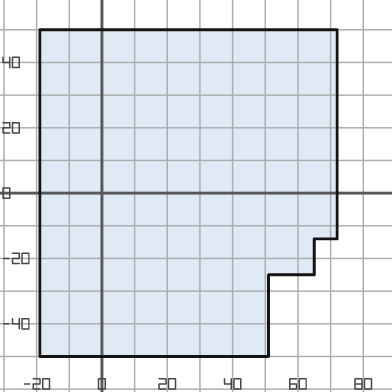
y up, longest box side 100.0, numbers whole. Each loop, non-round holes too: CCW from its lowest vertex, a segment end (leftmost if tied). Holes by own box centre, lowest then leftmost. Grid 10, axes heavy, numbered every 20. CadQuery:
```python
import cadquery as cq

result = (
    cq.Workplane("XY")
    .moveTo(-19.0, -50.0)
    .lineTo(51.0, -50.0)
    .lineTo(51.0, -25.0)
    .lineTo(65.0, -25.0)
    .lineTo(65.0, -14.0)
    .lineTo(72.0, -14.0)
    .lineTo(72.0, 50.0)
    .lineTo(-19.0, 50.0)
    .close()
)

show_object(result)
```